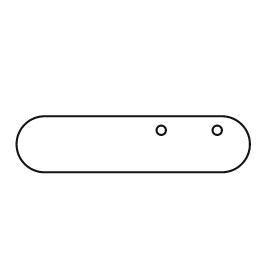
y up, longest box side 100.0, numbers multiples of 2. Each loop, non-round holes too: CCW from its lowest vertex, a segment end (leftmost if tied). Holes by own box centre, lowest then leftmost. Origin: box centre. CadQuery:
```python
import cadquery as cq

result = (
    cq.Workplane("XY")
    .moveTo(-38.0, -12.0)
    .lineTo(38.0, -12.0)
    .threePointArc((50.0, 0.0), (38.0, 12.0))
    .lineTo(-38.0, 12.0)
    .threePointArc((-50.0, 0.0), (-38.0, -12.0))
    .close()
    .moveTo(12.0, 6.0)
    .circle(2.0)
    .moveTo(36.0, 6.0)
    .circle(2.0)
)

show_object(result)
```